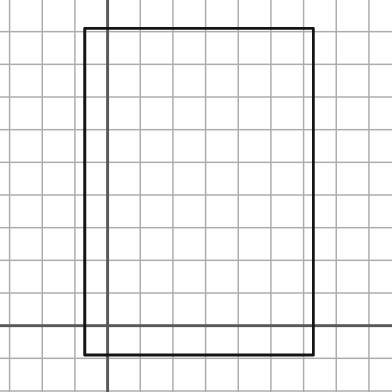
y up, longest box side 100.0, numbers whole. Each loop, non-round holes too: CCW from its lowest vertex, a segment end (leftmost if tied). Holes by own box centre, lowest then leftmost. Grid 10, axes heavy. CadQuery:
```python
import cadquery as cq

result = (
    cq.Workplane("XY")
    .moveTo(-7.0, -9.0)
    .lineTo(63.0, -9.0)
    .lineTo(63.0, 91.0)
    .lineTo(-7.0, 91.0)
    .close()
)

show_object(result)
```